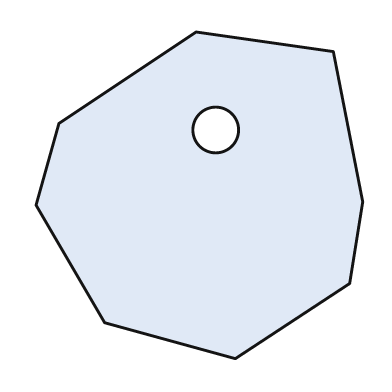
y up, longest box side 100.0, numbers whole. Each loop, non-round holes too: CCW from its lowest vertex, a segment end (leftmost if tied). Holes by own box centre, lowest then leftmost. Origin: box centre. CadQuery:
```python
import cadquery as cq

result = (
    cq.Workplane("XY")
    .moveTo(11.0, -50.0)
    .lineTo(46.0, -27.0)
    .lineTo(50.0, -2.0)
    .lineTo(41.0, 44.0)
    .lineTo(-1.0, 50.0)
    .lineTo(-43.0, 22.0)
    .lineTo(-50.0, -3.0)
    .lineTo(-29.0, -39.0)
    .close()
    .moveTo(5.0, 20.0)
    .circle(7.0)
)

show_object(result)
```